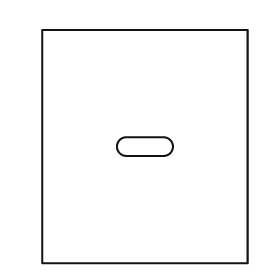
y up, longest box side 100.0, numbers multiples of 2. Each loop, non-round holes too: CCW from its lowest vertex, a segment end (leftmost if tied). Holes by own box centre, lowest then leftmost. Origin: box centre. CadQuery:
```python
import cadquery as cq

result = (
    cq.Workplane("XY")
    .moveTo(-44.0, -50.0)
    .lineTo(44.0, -50.0)
    .lineTo(44.0, 50.0)
    .lineTo(-44.0, 50.0)
    .close()
    .moveTo(-8.0, -4.0)
    .lineTo(8.0, -4.0)
    .threePointArc((12.0, 0.0), (8.0, 4.0))
    .lineTo(-8.0, 4.0)
    .threePointArc((-12.0, 0.0), (-8.0, -4.0))
    .close()
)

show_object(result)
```